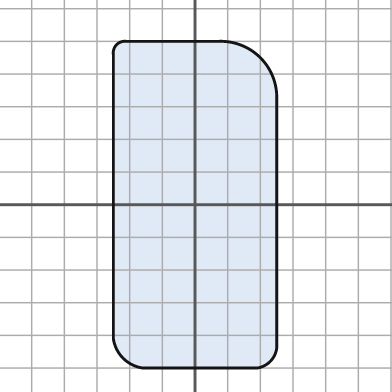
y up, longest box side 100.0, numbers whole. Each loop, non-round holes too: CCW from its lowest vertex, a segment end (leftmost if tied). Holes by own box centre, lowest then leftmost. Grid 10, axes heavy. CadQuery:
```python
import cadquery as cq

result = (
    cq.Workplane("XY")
    .moveTo(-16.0, -50.0)
    .lineTo(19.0, -50.0)
    .threePointArc((23.0, -48.0), (25.0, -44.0))
    .lineTo(25.0, 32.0)
    .threePointArc((20.0, 45.0), (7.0, 50.0))
    .lineTo(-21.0, 50.0)
    .threePointArc((-24.0, 49.0), (-25.0, 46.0))
    .lineTo(-25.0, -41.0)
    .threePointArc((-22.0, -47.0), (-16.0, -50.0))
    .close()
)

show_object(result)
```